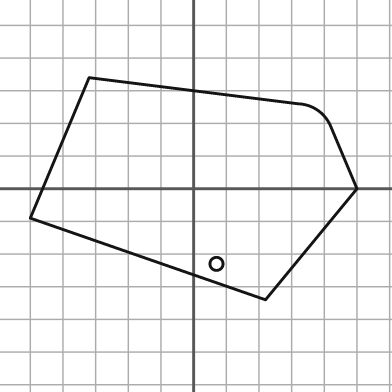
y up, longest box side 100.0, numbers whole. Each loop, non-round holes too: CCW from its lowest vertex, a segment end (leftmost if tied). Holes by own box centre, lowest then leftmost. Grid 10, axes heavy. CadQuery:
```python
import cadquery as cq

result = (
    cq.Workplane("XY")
    .moveTo(22.0, -34.0)
    .lineTo(50.0, 0.0)
    .lineTo(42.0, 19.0)
    .threePointArc((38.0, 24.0), (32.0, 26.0))
    .lineTo(-32.0, 34.0)
    .lineTo(-50.0, -9.0)
    .close()
    .moveTo(7.0, -23.0)
    .circle(2.0)
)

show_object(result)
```